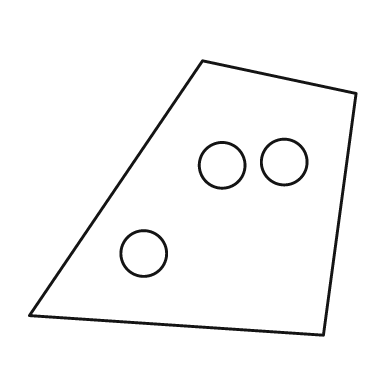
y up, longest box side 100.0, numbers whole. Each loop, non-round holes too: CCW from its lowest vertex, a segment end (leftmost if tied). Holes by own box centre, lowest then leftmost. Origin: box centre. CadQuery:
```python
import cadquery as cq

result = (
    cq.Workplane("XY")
    .moveTo(40.0, -42.0)
    .lineTo(50.0, 32.0)
    .lineTo(3.0, 42.0)
    .lineTo(-50.0, -36.0)
    .close()
    .moveTo(-15.0, -17.0)
    .circle(7.0)
    .moveTo(9.0, 10.0)
    .circle(7.0)
    .moveTo(28.0, 11.0)
    .circle(7.0)
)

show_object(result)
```